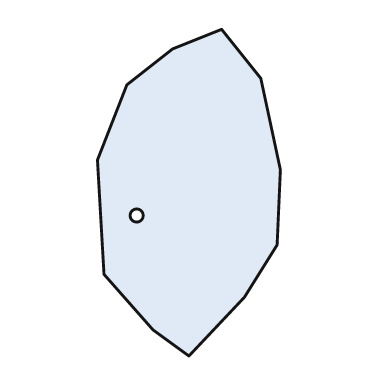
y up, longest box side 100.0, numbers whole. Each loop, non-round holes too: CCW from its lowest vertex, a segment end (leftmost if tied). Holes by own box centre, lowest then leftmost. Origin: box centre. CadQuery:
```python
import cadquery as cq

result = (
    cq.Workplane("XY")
    .moveTo(0.0, -50.0)
    .lineTo(17.0, -32.0)
    .lineTo(27.0, -16.0)
    .lineTo(28.0, 7.0)
    .lineTo(22.0, 35.0)
    .lineTo(10.0, 50.0)
    .lineTo(-5.0, 44.0)
    .lineTo(-19.0, 33.0)
    .lineTo(-28.0, 10.0)
    .lineTo(-26.0, -25.0)
    .lineTo(-11.0, -42.0)
    .close()
    .moveTo(-16.0, -7.0)
    .circle(2.0)
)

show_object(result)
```